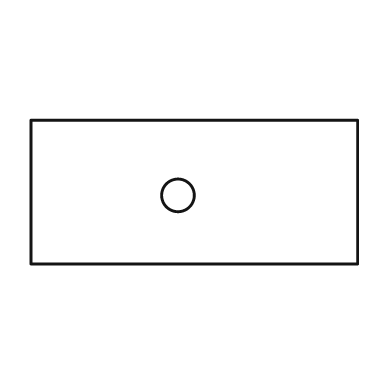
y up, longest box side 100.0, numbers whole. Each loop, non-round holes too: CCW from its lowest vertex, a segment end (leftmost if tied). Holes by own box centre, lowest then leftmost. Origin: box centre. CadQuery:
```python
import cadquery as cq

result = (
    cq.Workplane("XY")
    .moveTo(-50.0, -22.0)
    .lineTo(50.0, -22.0)
    .lineTo(50.0, 22.0)
    .lineTo(-50.0, 22.0)
    .close()
    .moveTo(-5.0, -1.0)
    .circle(5.0)
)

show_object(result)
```